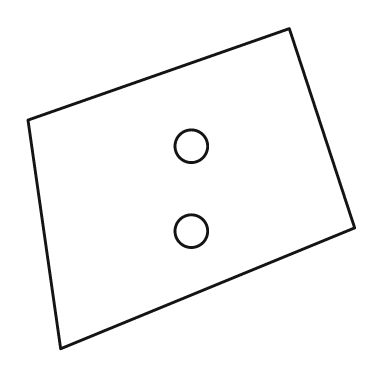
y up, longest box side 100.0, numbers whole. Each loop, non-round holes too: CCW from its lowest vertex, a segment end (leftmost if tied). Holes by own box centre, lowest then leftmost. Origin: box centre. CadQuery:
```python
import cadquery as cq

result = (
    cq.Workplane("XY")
    .moveTo(-40.0, -49.0)
    .lineTo(50.0, -12.0)
    .lineTo(30.0, 49.0)
    .lineTo(-50.0, 21.0)
    .close()
    .moveTo(0.0, -13.0)
    .circle(5.0)
    .moveTo(0.0, 13.0)
    .circle(5.0)
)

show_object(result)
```